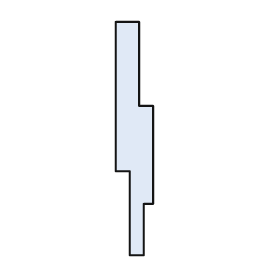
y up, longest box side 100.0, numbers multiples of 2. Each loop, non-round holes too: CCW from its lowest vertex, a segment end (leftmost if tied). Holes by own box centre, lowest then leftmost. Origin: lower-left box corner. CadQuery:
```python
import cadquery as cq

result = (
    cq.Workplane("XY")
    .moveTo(6.0, 0.0)
    .lineTo(12.0, 0.0)
    .lineTo(12.0, 22.0)
    .lineTo(16.0, 22.0)
    .lineTo(16.0, 64.0)
    .lineTo(10.0, 64.0)
    .lineTo(10.0, 100.0)
    .lineTo(0.0, 100.0)
    .lineTo(0.0, 36.0)
    .lineTo(6.0, 36.0)
    .close()
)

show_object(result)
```